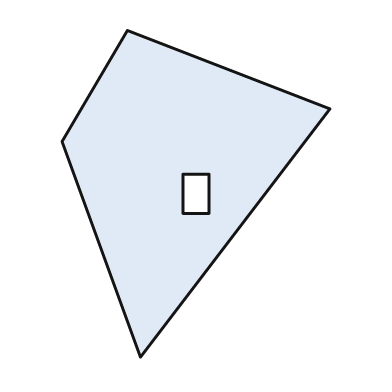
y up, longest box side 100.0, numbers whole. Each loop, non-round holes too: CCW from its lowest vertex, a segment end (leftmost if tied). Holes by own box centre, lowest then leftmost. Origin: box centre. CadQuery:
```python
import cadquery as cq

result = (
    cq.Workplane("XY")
    .moveTo(-17.0, -50.0)
    .lineTo(41.0, 26.0)
    .lineTo(-21.0, 50.0)
    .lineTo(-41.0, 16.0)
    .close()
    .moveTo(-4.0, -6.0)
    .lineTo(4.0, -6.0)
    .lineTo(4.0, 6.0)
    .lineTo(-4.0, 6.0)
    .close()
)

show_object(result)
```